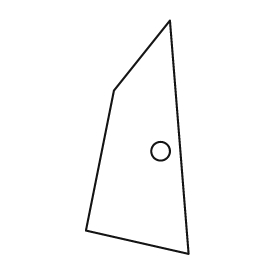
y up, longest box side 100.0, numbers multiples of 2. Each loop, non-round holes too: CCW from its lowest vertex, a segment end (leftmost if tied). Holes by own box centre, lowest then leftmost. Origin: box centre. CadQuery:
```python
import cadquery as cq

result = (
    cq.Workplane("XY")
    .moveTo(22.0, -50.0)
    .lineTo(14.0, 50.0)
    .lineTo(-10.0, 20.0)
    .lineTo(-22.0, -40.0)
    .close()
    .moveTo(10.0, -6.0)
    .circle(4.0)
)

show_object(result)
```